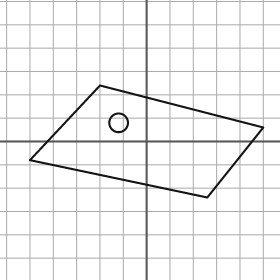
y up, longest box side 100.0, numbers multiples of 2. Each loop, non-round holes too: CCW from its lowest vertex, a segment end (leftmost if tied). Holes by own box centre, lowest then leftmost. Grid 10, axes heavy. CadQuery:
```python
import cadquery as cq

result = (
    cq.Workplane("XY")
    .moveTo(26.0, -24.0)
    .lineTo(50.0, 6.0)
    .lineTo(-20.0, 24.0)
    .lineTo(-50.0, -8.0)
    .close()
    .moveTo(-12.0, 8.0)
    .circle(4.0)
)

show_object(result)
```